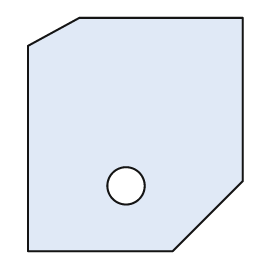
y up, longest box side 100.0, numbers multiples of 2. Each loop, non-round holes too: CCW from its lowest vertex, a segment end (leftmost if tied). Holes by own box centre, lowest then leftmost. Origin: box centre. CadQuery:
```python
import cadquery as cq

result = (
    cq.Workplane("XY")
    .moveTo(-46.0, -50.0)
    .lineTo(16.0, -50.0)
    .lineTo(46.0, -20.0)
    .lineTo(46.0, 50.0)
    .lineTo(-24.0, 50.0)
    .lineTo(-46.0, 38.0)
    .close()
    .moveTo(-4.0, -22.0)
    .circle(8.0)
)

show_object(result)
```